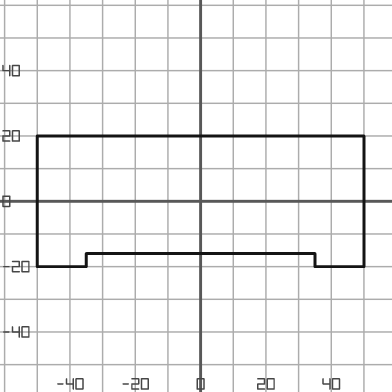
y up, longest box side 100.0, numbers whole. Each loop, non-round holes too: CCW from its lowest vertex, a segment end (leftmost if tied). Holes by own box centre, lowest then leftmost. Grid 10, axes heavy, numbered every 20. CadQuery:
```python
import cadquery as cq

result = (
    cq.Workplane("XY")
    .moveTo(-50.0, -20.0)
    .lineTo(-35.0, -20.0)
    .lineTo(-35.0, -16.0)
    .lineTo(35.0, -16.0)
    .lineTo(35.0, -20.0)
    .lineTo(50.0, -20.0)
    .lineTo(50.0, 20.0)
    .lineTo(-50.0, 20.0)
    .close()
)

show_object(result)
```